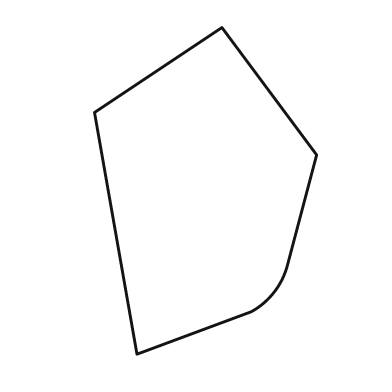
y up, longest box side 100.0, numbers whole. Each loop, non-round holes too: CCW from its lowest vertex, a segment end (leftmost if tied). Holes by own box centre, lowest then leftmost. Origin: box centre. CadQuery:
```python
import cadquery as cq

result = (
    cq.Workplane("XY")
    .moveTo(-21.0, -50.0)
    .lineTo(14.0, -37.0)
    .threePointArc((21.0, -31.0), (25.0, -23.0))
    .lineTo(34.0, 11.0)
    .lineTo(5.0, 50.0)
    .lineTo(-34.0, 24.0)
    .close()
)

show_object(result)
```